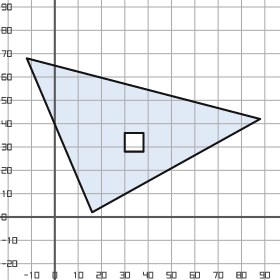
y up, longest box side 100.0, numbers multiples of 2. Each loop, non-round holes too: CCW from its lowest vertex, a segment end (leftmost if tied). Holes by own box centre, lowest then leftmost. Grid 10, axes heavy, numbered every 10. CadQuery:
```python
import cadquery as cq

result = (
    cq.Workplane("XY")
    .moveTo(16.0, 2.0)
    .lineTo(88.0, 42.0)
    .lineTo(-12.0, 68.0)
    .close()
    .moveTo(30.0, 28.0)
    .lineTo(38.0, 28.0)
    .lineTo(38.0, 36.0)
    .lineTo(30.0, 36.0)
    .close()
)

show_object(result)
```